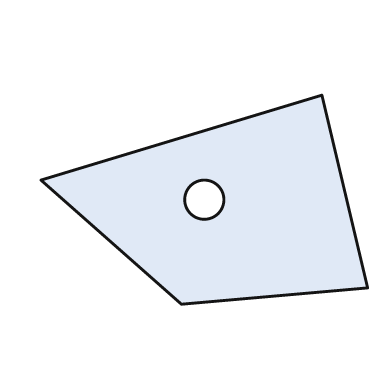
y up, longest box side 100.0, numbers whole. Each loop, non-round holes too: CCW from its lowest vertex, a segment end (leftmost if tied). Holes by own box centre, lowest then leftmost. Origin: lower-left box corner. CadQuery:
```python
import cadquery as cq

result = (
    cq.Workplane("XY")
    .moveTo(43.0, 0.0)
    .lineTo(100.0, 5.0)
    .lineTo(86.0, 64.0)
    .lineTo(0.0, 38.0)
    .close()
    .moveTo(50.0, 32.0)
    .circle(6.0)
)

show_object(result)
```